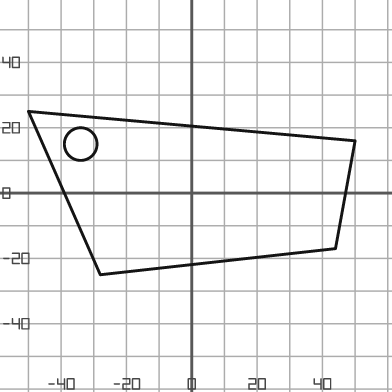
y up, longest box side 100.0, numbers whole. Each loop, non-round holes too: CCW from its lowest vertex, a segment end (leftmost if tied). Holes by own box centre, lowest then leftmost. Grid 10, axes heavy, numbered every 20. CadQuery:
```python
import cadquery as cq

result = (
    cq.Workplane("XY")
    .moveTo(-28.0, -25.0)
    .lineTo(44.0, -17.0)
    .lineTo(50.0, 16.0)
    .lineTo(-50.0, 25.0)
    .close()
    .moveTo(-34.0, 15.0)
    .circle(5.0)
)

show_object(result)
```